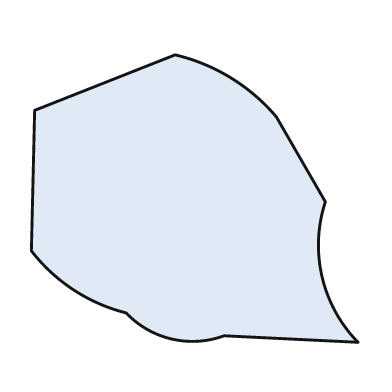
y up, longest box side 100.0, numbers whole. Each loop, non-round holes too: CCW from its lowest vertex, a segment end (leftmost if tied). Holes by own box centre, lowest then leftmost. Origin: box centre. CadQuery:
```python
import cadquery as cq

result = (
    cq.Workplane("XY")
    .moveTo(50.0, -44.0)
    .threePointArc((39.0, -24.0), (40.0, -1.0))
    .lineTo(25.0, 25.0)
    .threePointArc((11.0, 37.0), (-6.0, 44.0))
    .lineTo(-49.0, 27.0)
    .lineTo(-50.0, -16.0)
    .threePointArc((-37.0, -28.0), (-21.0, -35.0))
    .threePointArc((-7.0, -43.0), (9.0, -42.0))
    .close()
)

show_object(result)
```